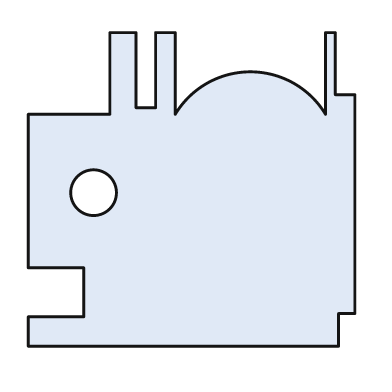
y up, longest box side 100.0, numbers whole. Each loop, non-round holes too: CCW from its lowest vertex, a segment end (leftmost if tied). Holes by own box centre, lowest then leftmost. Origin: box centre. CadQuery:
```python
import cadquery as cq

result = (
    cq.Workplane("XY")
    .moveTo(-50.0, -48.0)
    .lineTo(45.0, -48.0)
    .lineTo(45.0, -38.0)
    .lineTo(50.0, -38.0)
    .lineTo(50.0, 29.0)
    .lineTo(44.0, 29.0)
    .lineTo(44.0, 48.0)
    .lineTo(41.0, 48.0)
    .lineTo(41.0, 23.0)
    .threePointArc((18.0, 36.0), (-5.0, 23.0))
    .lineTo(-5.0, 48.0)
    .lineTo(-11.0, 48.0)
    .lineTo(-11.0, 25.0)
    .lineTo(-17.0, 25.0)
    .lineTo(-17.0, 48.0)
    .lineTo(-25.0, 48.0)
    .lineTo(-25.0, 23.0)
    .lineTo(-50.0, 23.0)
    .lineTo(-50.0, -24.0)
    .lineTo(-33.0, -24.0)
    .lineTo(-33.0, -39.0)
    .lineTo(-50.0, -39.0)
    .close()
    .moveTo(-30.0, -1.0)
    .circle(7.0)
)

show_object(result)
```